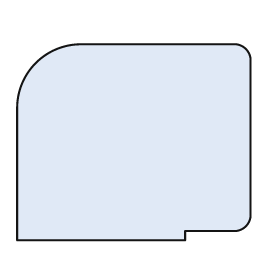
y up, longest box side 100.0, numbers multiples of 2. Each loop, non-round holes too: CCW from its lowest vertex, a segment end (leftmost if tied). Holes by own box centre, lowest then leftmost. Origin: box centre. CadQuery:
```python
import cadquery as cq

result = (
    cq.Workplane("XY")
    .moveTo(-50.0, -42.0)
    .lineTo(22.0, -42.0)
    .lineTo(22.0, -38.0)
    .lineTo(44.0, -38.0)
    .threePointArc((48.0, -36.0), (50.0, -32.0))
    .lineTo(50.0, 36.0)
    .threePointArc((48.0, 40.0), (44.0, 42.0))
    .lineTo(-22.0, 42.0)
    .threePointArc((-42.0, 34.0), (-50.0, 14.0))
    .close()
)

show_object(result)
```